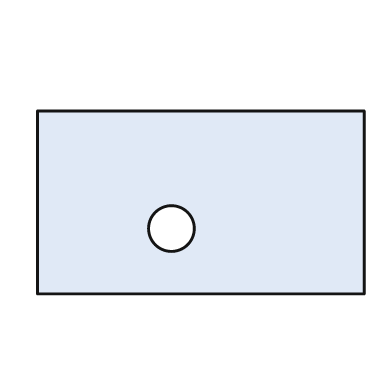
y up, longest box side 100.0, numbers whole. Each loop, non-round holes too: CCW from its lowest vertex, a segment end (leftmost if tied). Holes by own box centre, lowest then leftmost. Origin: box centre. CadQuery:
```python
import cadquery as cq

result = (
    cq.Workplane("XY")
    .moveTo(-50.0, -28.0)
    .lineTo(50.0, -28.0)
    .lineTo(50.0, 28.0)
    .lineTo(-50.0, 28.0)
    .close()
    .moveTo(-9.0, -8.0)
    .circle(7.0)
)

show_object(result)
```